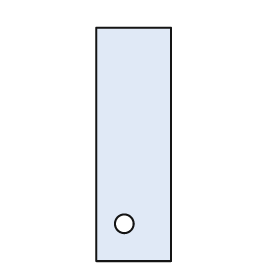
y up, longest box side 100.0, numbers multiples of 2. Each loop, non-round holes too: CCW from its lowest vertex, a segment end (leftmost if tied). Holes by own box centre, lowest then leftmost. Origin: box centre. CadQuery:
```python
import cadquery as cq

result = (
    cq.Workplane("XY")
    .moveTo(-16.0, -50.0)
    .lineTo(16.0, -50.0)
    .lineTo(16.0, 50.0)
    .lineTo(-16.0, 50.0)
    .close()
    .moveTo(-4.0, -34.0)
    .circle(4.0)
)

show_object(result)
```